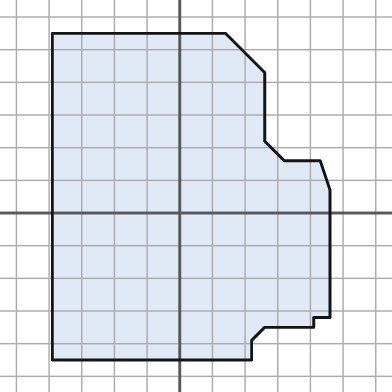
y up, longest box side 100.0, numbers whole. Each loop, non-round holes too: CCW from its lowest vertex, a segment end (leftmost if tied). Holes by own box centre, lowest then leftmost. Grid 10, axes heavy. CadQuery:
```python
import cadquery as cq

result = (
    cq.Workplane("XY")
    .moveTo(-39.0, -45.0)
    .lineTo(22.0, -45.0)
    .lineTo(22.0, -39.0)
    .lineTo(26.0, -35.0)
    .lineTo(41.0, -35.0)
    .lineTo(41.0, -32.0)
    .lineTo(46.0, -32.0)
    .lineTo(46.0, 7.0)
    .lineTo(43.0, 16.0)
    .lineTo(32.0, 16.0)
    .lineTo(26.0, 22.0)
    .lineTo(26.0, 43.0)
    .lineTo(14.0, 55.0)
    .lineTo(-39.0, 55.0)
    .close()
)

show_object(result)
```